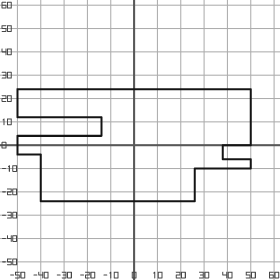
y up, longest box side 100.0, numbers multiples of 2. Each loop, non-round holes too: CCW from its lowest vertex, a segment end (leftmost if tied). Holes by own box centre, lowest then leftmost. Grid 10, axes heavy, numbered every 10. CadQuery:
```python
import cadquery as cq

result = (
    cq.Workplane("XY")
    .moveTo(-40.0, -24.0)
    .lineTo(26.0, -24.0)
    .lineTo(26.0, -10.0)
    .lineTo(50.0, -10.0)
    .lineTo(50.0, -6.0)
    .lineTo(38.0, -6.0)
    .lineTo(38.0, 0.0)
    .lineTo(50.0, 0.0)
    .lineTo(50.0, 24.0)
    .lineTo(-50.0, 24.0)
    .lineTo(-50.0, 12.0)
    .lineTo(-14.0, 12.0)
    .lineTo(-14.0, 4.0)
    .lineTo(-50.0, 4.0)
    .lineTo(-50.0, -4.0)
    .lineTo(-40.0, -4.0)
    .close()
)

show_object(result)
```